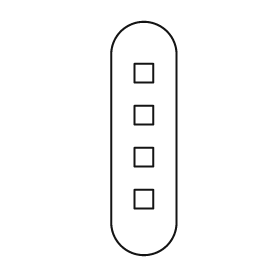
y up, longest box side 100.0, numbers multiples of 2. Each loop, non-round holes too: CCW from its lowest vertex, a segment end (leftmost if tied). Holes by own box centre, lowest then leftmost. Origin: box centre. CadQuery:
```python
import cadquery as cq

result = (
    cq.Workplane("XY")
    .moveTo(-14.0, -36.0)
    .threePointArc((0.0, -50.0), (14.0, -36.0))
    .lineTo(14.0, 36.0)
    .threePointArc((0.0, 50.0), (-14.0, 36.0))
    .close()
    .moveTo(-4.0, -30.0)
    .lineTo(4.0, -30.0)
    .lineTo(4.0, -22.0)
    .lineTo(-4.0, -22.0)
    .close()
    .moveTo(-4.0, -12.0)
    .lineTo(4.0, -12.0)
    .lineTo(4.0, -4.0)
    .lineTo(-4.0, -4.0)
    .close()
    .moveTo(-4.0, 6.0)
    .lineTo(4.0, 6.0)
    .lineTo(4.0, 14.0)
    .lineTo(-4.0, 14.0)
    .close()
    .moveTo(-4.0, 24.0)
    .lineTo(4.0, 24.0)
    .lineTo(4.0, 32.0)
    .lineTo(-4.0, 32.0)
    .close()
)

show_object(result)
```